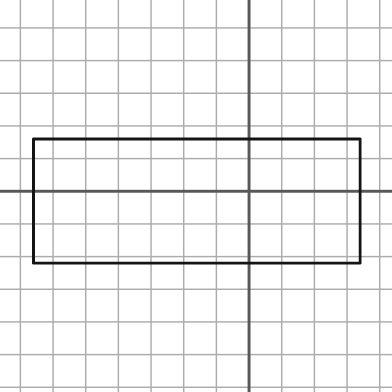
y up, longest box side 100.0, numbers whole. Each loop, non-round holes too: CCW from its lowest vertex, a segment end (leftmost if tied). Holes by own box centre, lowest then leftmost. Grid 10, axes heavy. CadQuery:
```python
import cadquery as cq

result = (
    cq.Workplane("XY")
    .moveTo(-66.0, -22.0)
    .lineTo(34.0, -22.0)
    .lineTo(34.0, 16.0)
    .lineTo(-66.0, 16.0)
    .close()
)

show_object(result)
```